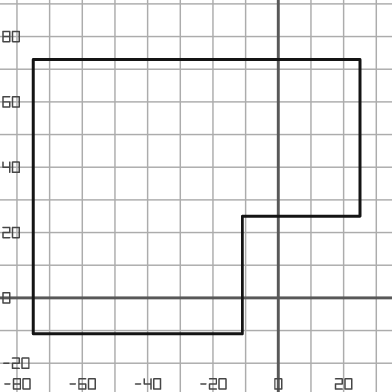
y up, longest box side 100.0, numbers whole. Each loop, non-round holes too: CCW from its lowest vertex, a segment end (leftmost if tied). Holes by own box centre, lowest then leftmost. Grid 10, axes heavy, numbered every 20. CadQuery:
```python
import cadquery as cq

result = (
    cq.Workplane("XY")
    .moveTo(-75.0, -11.0)
    .lineTo(-11.0, -11.0)
    .lineTo(-11.0, 25.0)
    .lineTo(25.0, 25.0)
    .lineTo(25.0, 73.0)
    .lineTo(-75.0, 73.0)
    .close()
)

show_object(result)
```